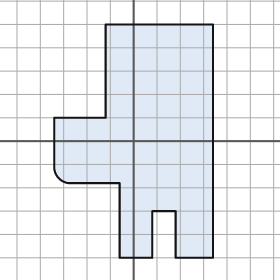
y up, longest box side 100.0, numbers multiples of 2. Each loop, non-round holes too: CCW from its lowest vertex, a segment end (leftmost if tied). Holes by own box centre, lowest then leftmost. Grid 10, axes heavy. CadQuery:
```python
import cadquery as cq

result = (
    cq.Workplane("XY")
    .moveTo(-6.0, -50.0)
    .lineTo(8.0, -50.0)
    .lineTo(8.0, -30.0)
    .lineTo(18.0, -30.0)
    .lineTo(18.0, -50.0)
    .lineTo(34.0, -50.0)
    .lineTo(34.0, 50.0)
    .lineTo(-12.0, 50.0)
    .lineTo(-12.0, 10.0)
    .lineTo(-34.0, 10.0)
    .lineTo(-34.0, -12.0)
    .threePointArc((-32.0, -16.0), (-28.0, -18.0))
    .lineTo(-6.0, -18.0)
    .close()
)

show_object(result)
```